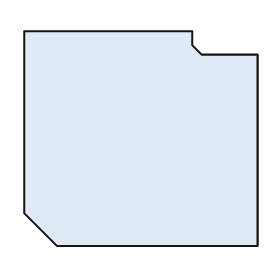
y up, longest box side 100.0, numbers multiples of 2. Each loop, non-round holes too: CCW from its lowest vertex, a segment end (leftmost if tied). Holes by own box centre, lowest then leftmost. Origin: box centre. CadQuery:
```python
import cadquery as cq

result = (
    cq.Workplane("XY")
    .moveTo(-36.0, -46.0)
    .lineTo(50.0, -46.0)
    .lineTo(50.0, 36.0)
    .lineTo(26.0, 36.0)
    .lineTo(22.0, 40.0)
    .lineTo(22.0, 46.0)
    .lineTo(-50.0, 46.0)
    .lineTo(-50.0, -32.0)
    .close()
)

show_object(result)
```